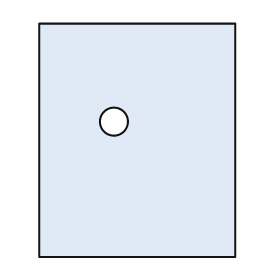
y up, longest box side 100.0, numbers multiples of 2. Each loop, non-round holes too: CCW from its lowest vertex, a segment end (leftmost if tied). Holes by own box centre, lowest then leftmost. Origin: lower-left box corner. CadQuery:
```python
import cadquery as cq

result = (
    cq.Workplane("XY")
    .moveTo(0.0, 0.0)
    .lineTo(84.0, 0.0)
    .lineTo(84.0, 100.0)
    .lineTo(0.0, 100.0)
    .close()
    .moveTo(32.0, 58.0)
    .circle(6.0)
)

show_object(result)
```